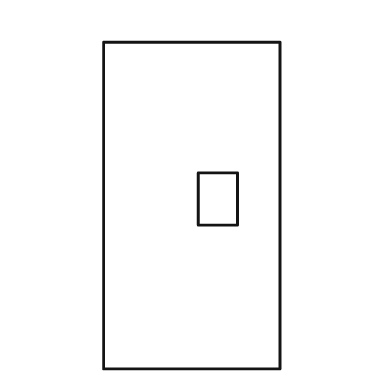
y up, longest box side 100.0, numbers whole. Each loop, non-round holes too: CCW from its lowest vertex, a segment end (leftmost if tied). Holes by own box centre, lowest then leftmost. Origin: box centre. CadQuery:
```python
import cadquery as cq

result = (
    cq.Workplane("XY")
    .moveTo(-27.0, -50.0)
    .lineTo(27.0, -50.0)
    .lineTo(27.0, 50.0)
    .lineTo(-27.0, 50.0)
    .close()
    .moveTo(2.0, -6.0)
    .lineTo(14.0, -6.0)
    .lineTo(14.0, 10.0)
    .lineTo(2.0, 10.0)
    .close()
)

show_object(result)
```